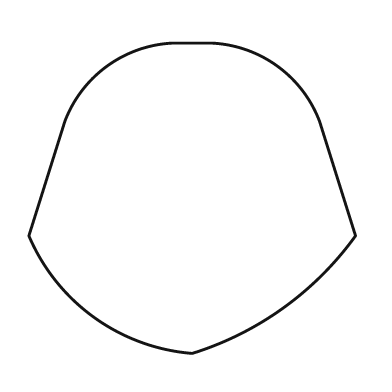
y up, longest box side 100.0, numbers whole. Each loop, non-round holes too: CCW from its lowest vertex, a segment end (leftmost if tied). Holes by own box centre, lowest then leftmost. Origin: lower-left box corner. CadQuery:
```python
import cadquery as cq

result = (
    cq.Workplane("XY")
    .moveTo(50.0, 0.0)
    .threePointArc((78.0, 14.0), (100.0, 36.0))
    .lineTo(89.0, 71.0)
    .threePointArc((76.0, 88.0), (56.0, 95.0))
    .lineTo(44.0, 95.0)
    .threePointArc((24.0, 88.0), (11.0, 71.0))
    .lineTo(0.0, 36.0)
    .threePointArc((20.0, 11.0), (50.0, 0.0))
    .close()
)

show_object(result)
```